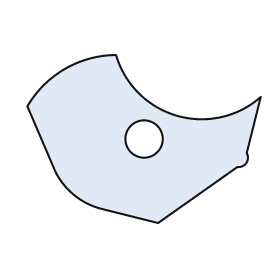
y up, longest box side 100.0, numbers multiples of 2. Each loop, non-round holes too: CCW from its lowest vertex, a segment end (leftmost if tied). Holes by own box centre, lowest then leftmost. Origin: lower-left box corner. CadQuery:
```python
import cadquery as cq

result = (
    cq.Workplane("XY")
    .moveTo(56.0, 0.0)
    .lineTo(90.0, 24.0)
    .threePointArc((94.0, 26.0), (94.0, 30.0))
    .lineTo(100.0, 54.0)
    .threePointArc((64.0, 46.0), (38.0, 72.0))
    .threePointArc((16.0, 66.0), (0.0, 50.0))
    .lineTo(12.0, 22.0)
    .threePointArc((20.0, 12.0), (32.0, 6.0))
    .close()
    .moveTo(50.0, 36.0)
    .circle(8.0)
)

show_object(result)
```